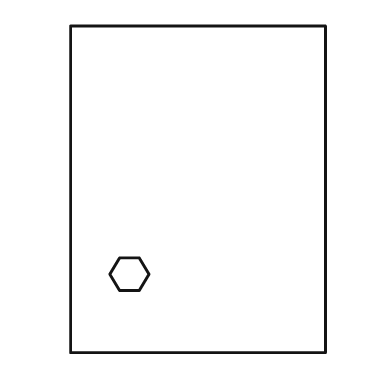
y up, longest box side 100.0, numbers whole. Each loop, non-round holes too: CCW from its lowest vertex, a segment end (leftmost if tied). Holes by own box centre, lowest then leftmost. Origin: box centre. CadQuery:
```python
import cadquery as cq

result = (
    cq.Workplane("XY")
    .moveTo(-39.0, -50.0)
    .lineTo(39.0, -50.0)
    .lineTo(39.0, 50.0)
    .lineTo(-39.0, 50.0)
    .close()
    .moveTo(-24.0, -31.0)
    .lineTo(-18.0, -31.0)
    .lineTo(-15.0, -26.0)
    .lineTo(-18.0, -21.0)
    .lineTo(-24.0, -21.0)
    .lineTo(-27.0, -26.0)
    .close()
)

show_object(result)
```